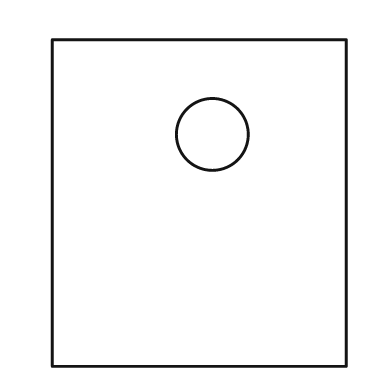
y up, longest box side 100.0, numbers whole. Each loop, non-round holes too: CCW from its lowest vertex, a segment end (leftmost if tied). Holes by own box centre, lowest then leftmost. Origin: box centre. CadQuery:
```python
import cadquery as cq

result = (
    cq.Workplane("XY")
    .moveTo(-45.0, -50.0)
    .lineTo(45.0, -50.0)
    .lineTo(45.0, 50.0)
    .lineTo(-45.0, 50.0)
    .close()
    .moveTo(4.0, 21.0)
    .circle(11.0)
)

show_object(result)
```